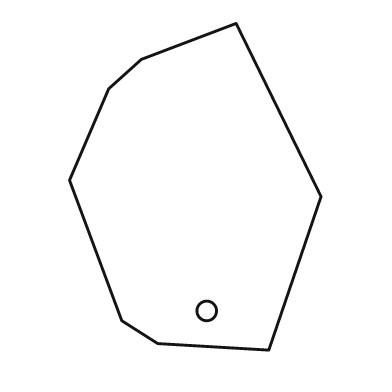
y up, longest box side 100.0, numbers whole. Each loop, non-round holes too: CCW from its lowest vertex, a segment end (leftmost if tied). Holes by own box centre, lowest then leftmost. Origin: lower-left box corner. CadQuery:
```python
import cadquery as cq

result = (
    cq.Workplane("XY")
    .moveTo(61.0, 0.0)
    .lineTo(77.0, 47.0)
    .lineTo(51.0, 100.0)
    .lineTo(22.0, 89.0)
    .lineTo(12.0, 80.0)
    .lineTo(0.0, 52.0)
    .lineTo(16.0, 9.0)
    .lineTo(27.0, 2.0)
    .close()
    .moveTo(42.0, 12.0)
    .circle(3.0)
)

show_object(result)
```